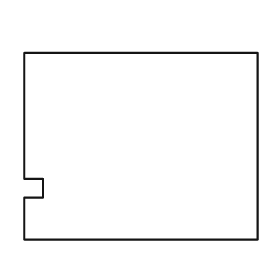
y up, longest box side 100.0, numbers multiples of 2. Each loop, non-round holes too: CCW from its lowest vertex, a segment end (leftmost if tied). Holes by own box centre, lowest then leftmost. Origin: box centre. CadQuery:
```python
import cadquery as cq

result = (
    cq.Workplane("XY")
    .moveTo(-50.0, -40.0)
    .lineTo(50.0, -40.0)
    .lineTo(50.0, 40.0)
    .lineTo(-50.0, 40.0)
    .lineTo(-50.0, -14.0)
    .lineTo(-42.0, -14.0)
    .lineTo(-42.0, -22.0)
    .lineTo(-50.0, -22.0)
    .close()
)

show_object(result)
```